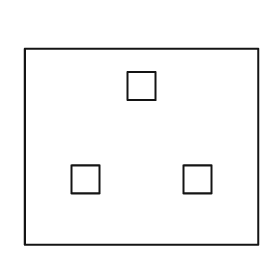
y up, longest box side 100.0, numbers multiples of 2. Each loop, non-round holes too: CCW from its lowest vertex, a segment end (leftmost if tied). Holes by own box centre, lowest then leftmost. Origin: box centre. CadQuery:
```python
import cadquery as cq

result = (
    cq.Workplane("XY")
    .moveTo(-50.0, -42.0)
    .lineTo(50.0, -42.0)
    .lineTo(50.0, 42.0)
    .lineTo(-50.0, 42.0)
    .close()
    .moveTo(-30.0, -20.0)
    .lineTo(-18.0, -20.0)
    .lineTo(-18.0, -8.0)
    .lineTo(-30.0, -8.0)
    .close()
    .moveTo(18.0, -20.0)
    .lineTo(30.0, -20.0)
    .lineTo(30.0, -8.0)
    .lineTo(18.0, -8.0)
    .close()
    .moveTo(-6.0, 20.0)
    .lineTo(6.0, 20.0)
    .lineTo(6.0, 32.0)
    .lineTo(-6.0, 32.0)
    .close()
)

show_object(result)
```